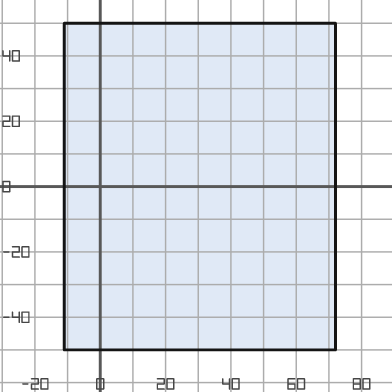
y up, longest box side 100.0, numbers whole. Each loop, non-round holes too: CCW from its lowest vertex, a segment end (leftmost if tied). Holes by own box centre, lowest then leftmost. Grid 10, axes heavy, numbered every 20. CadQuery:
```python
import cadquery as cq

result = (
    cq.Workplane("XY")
    .moveTo(-11.0, -50.0)
    .lineTo(72.0, -50.0)
    .lineTo(72.0, 50.0)
    .lineTo(-11.0, 50.0)
    .close()
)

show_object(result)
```